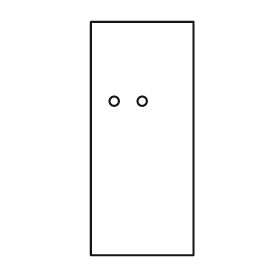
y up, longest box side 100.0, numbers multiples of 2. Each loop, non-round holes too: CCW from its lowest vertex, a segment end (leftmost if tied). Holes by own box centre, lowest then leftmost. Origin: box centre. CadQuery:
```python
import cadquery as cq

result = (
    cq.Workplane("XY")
    .moveTo(-22.0, -50.0)
    .lineTo(22.0, -50.0)
    .lineTo(22.0, 50.0)
    .lineTo(-22.0, 50.0)
    .close()
    .moveTo(-12.0, 16.0)
    .circle(2.0)
    .moveTo(0.0, 16.0)
    .circle(2.0)
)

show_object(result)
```